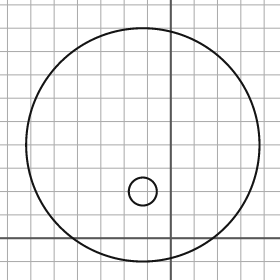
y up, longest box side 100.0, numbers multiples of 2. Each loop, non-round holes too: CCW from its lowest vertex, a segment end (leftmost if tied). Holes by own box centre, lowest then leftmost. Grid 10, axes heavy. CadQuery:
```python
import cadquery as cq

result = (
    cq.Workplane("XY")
    .moveTo(-12.0, 40.0)
    .circle(50.0)
    .moveTo(-12.0, 20.0)
    .circle(6.0)
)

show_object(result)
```